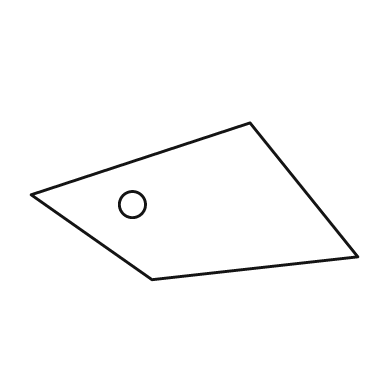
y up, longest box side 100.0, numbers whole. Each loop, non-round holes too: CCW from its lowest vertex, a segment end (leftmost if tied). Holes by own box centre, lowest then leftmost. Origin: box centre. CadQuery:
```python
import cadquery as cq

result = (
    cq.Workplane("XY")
    .moveTo(-13.0, -24.0)
    .lineTo(50.0, -17.0)
    .lineTo(17.0, 24.0)
    .lineTo(-50.0, 2.0)
    .close()
    .moveTo(-19.0, -1.0)
    .circle(4.0)
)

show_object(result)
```